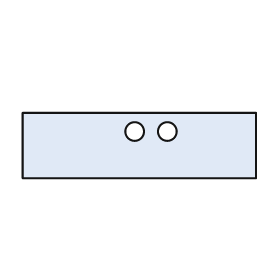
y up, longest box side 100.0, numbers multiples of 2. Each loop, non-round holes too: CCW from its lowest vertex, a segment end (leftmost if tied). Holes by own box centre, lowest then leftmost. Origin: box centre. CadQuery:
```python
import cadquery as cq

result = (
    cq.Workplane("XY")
    .moveTo(-50.0, -14.0)
    .lineTo(50.0, -14.0)
    .lineTo(50.0, 14.0)
    .lineTo(-50.0, 14.0)
    .close()
    .moveTo(-2.0, 6.0)
    .circle(4.0)
    .moveTo(12.0, 6.0)
    .circle(4.0)
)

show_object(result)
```